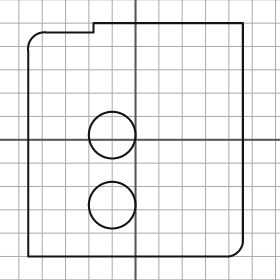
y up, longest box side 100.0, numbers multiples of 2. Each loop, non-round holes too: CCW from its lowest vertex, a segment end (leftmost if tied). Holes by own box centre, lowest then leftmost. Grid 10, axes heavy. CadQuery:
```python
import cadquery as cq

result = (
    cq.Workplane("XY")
    .moveTo(-46.0, -50.0)
    .lineTo(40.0, -50.0)
    .threePointArc((44.0, -48.0), (46.0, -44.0))
    .lineTo(46.0, 50.0)
    .lineTo(-18.0, 50.0)
    .lineTo(-18.0, 46.0)
    .lineTo(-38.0, 46.0)
    .threePointArc((-44.0, 44.0), (-46.0, 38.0))
    .close()
    .moveTo(-10.0, -28.0)
    .circle(10.0)
    .moveTo(-10.0, 2.0)
    .circle(10.0)
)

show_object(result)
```